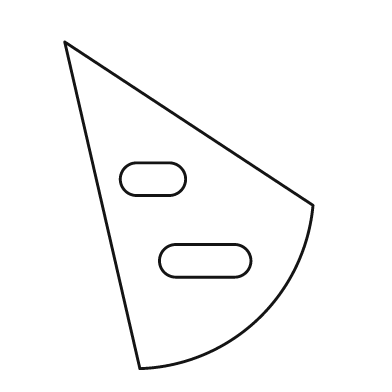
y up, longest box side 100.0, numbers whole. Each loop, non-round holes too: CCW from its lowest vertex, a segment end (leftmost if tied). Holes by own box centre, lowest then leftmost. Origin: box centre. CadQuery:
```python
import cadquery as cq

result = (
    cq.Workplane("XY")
    .moveTo(-15.0, -50.0)
    .threePointArc((21.0, -35.0), (38.0, 0.0))
    .lineTo(-38.0, 50.0)
    .close()
    .moveTo(-4.0, -22.0)
    .lineTo(14.0, -22.0)
    .threePointArc((19.0, -17.0), (14.0, -12.0))
    .lineTo(-4.0, -12.0)
    .threePointArc((-9.0, -17.0), (-4.0, -22.0))
    .close()
    .moveTo(-16.0, 3.0)
    .lineTo(-6.0, 3.0)
    .threePointArc((-1.0, 8.0), (-6.0, 13.0))
    .lineTo(-16.0, 13.0)
    .threePointArc((-21.0, 8.0), (-16.0, 3.0))
    .close()
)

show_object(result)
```